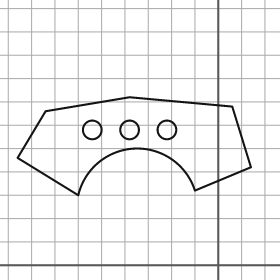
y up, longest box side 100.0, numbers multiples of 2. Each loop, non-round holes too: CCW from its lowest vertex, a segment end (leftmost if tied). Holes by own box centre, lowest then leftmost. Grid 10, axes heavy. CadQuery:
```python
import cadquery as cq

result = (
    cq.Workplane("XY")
    .moveTo(-60.0, 30.0)
    .threePointArc((-36.0, 50.0), (-10.0, 32.0))
    .lineTo(14.0, 42.0)
    .lineTo(6.0, 68.0)
    .lineTo(-38.0, 72.0)
    .lineTo(-74.0, 66.0)
    .lineTo(-86.0, 46.0)
    .close()
    .moveTo(-54.0, 58.0)
    .circle(4.0)
    .moveTo(-38.0, 58.0)
    .circle(4.0)
    .moveTo(-22.0, 58.0)
    .circle(4.0)
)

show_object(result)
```